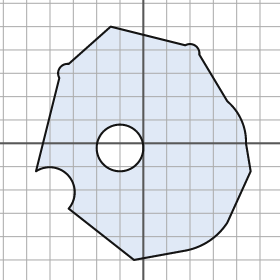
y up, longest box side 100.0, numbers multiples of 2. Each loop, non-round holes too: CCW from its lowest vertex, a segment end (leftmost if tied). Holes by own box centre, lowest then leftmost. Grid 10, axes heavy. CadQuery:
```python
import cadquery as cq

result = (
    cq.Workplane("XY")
    .moveTo(-4.0, -50.0)
    .lineTo(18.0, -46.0)
    .threePointArc((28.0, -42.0), (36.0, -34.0))
    .lineTo(46.0, -12.0)
    .lineTo(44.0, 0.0)
    .threePointArc((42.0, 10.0), (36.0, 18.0))
    .lineTo(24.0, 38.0)
    .threePointArc((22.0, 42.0), (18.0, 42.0))
    .lineTo(-14.0, 50.0)
    .lineTo(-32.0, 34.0)
    .threePointArc((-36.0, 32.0), (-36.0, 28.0))
    .lineTo(-46.0, -12.0)
    .threePointArc((-32.0, -14.0), (-32.0, -28.0))
    .close()
    .moveTo(-10.0, -2.0)
    .circle(10.0)
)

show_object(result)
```